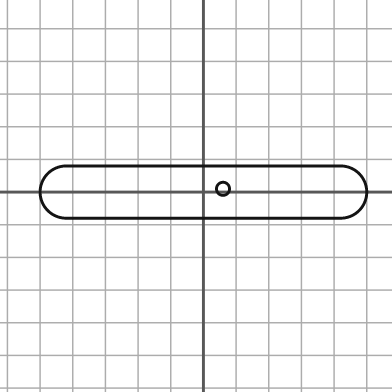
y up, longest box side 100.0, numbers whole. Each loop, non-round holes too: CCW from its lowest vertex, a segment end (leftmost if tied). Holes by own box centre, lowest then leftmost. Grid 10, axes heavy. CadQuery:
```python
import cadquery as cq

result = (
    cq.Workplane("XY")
    .moveTo(-42.0, -8.0)
    .lineTo(42.0, -8.0)
    .threePointArc((50.0, 0.0), (42.0, 8.0))
    .lineTo(-42.0, 8.0)
    .threePointArc((-50.0, 0.0), (-42.0, -8.0))
    .close()
    .moveTo(6.0, 1.0)
    .circle(2.0)
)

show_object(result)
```